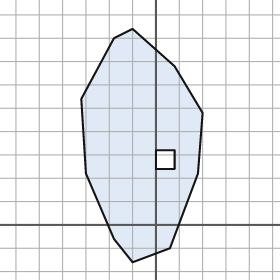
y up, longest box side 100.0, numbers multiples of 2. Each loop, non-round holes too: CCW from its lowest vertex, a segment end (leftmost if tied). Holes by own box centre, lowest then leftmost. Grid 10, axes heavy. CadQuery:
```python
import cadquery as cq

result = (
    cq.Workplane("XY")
    .moveTo(-10.0, -16.0)
    .lineTo(6.0, -10.0)
    .lineTo(18.0, 22.0)
    .lineTo(20.0, 48.0)
    .lineTo(8.0, 68.0)
    .lineTo(-10.0, 84.0)
    .lineTo(-18.0, 80.0)
    .lineTo(-32.0, 54.0)
    .lineTo(-30.0, 22.0)
    .lineTo(-18.0, -6.0)
    .close()
    .moveTo(0.0, 24.0)
    .lineTo(8.0, 24.0)
    .lineTo(8.0, 32.0)
    .lineTo(0.0, 32.0)
    .close()
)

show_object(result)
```